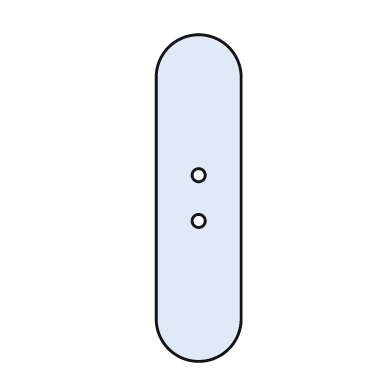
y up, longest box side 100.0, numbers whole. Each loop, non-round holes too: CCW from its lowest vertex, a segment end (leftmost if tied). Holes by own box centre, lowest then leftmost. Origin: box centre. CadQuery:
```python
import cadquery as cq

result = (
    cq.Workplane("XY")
    .moveTo(-13.0, -37.0)
    .threePointArc((0.0, -50.0), (13.0, -37.0))
    .lineTo(13.0, 37.0)
    .threePointArc((0.0, 50.0), (-13.0, 37.0))
    .close()
    .moveTo(0.0, -7.0)
    .circle(2.0)
    .moveTo(0.0, 7.0)
    .circle(2.0)
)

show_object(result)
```